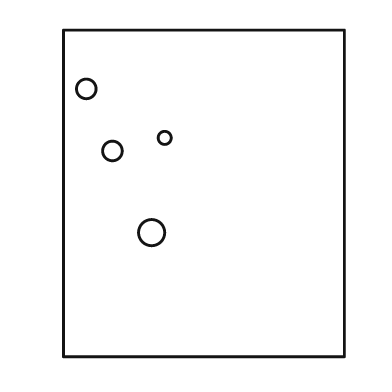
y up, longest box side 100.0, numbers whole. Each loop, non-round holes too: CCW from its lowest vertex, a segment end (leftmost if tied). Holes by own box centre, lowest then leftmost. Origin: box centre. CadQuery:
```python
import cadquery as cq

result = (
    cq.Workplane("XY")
    .moveTo(-43.0, -50.0)
    .lineTo(43.0, -50.0)
    .lineTo(43.0, 50.0)
    .lineTo(-43.0, 50.0)
    .close()
    .moveTo(-16.0, -12.0)
    .circle(4.0)
    .moveTo(-28.0, 13.0)
    .circle(3.0)
    .moveTo(-12.0, 17.0)
    .circle(2.0)
    .moveTo(-36.0, 32.0)
    .circle(3.0)
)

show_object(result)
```